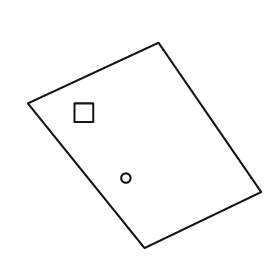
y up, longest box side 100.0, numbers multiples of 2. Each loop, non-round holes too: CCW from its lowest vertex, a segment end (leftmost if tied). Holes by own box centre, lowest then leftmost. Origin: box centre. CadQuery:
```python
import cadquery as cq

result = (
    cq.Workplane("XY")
    .moveTo(0.0, -44.0)
    .lineTo(50.0, -20.0)
    .lineTo(6.0, 44.0)
    .lineTo(-50.0, 18.0)
    .close()
    .moveTo(-8.0, -14.0)
    .circle(2.0)
    .moveTo(-30.0, 10.0)
    .lineTo(-22.0, 10.0)
    .lineTo(-22.0, 18.0)
    .lineTo(-30.0, 18.0)
    .close()
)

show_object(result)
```